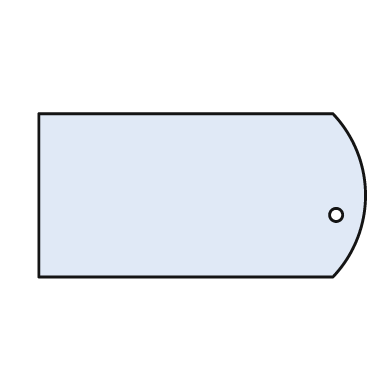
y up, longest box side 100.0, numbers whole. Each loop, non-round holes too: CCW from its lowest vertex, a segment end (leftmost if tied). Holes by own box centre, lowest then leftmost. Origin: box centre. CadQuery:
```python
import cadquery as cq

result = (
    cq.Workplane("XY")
    .moveTo(-50.0, -25.0)
    .lineTo(40.0, -25.0)
    .threePointArc((50.0, 0.0), (40.0, 25.0))
    .lineTo(-50.0, 25.0)
    .close()
    .moveTo(41.0, -6.0)
    .circle(2.0)
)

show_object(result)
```